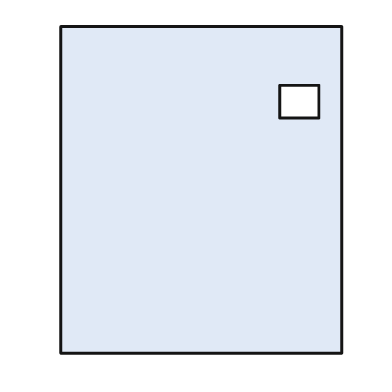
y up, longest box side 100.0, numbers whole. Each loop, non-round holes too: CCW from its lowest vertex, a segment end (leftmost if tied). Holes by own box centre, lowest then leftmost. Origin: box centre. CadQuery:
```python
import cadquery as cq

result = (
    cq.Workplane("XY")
    .moveTo(-43.0, -50.0)
    .lineTo(43.0, -50.0)
    .lineTo(43.0, 50.0)
    .lineTo(-43.0, 50.0)
    .close()
    .moveTo(24.0, 22.0)
    .lineTo(36.0, 22.0)
    .lineTo(36.0, 32.0)
    .lineTo(24.0, 32.0)
    .close()
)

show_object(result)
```